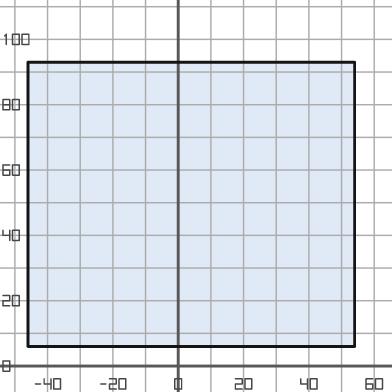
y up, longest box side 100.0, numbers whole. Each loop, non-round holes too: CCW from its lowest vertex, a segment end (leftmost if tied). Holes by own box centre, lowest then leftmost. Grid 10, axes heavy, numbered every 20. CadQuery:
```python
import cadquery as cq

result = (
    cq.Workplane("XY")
    .moveTo(-46.0, 6.0)
    .lineTo(54.0, 6.0)
    .lineTo(54.0, 93.0)
    .lineTo(-46.0, 93.0)
    .close()
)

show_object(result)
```